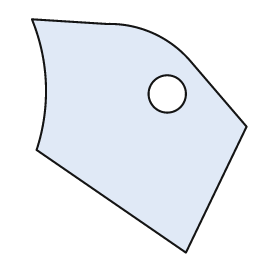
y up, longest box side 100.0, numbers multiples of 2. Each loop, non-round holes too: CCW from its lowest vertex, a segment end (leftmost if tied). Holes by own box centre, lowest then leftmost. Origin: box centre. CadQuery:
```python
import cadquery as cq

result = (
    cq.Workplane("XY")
    .moveTo(20.0, -50.0)
    .lineTo(46.0, 4.0)
    .lineTo(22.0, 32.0)
    .threePointArc((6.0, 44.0), (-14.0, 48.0))
    .lineTo(-46.0, 50.0)
    .threePointArc((-40.0, 22.0), (-44.0, -6.0))
    .close()
    .moveTo(12.0, 18.0)
    .circle(8.0)
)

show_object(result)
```